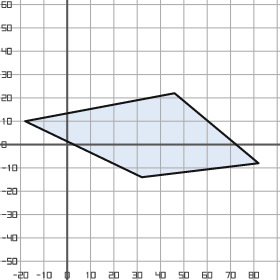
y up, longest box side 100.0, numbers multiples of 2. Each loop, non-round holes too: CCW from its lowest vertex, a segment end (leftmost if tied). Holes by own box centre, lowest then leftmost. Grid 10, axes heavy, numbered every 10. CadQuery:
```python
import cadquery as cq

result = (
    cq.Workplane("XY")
    .moveTo(32.0, -14.0)
    .lineTo(82.0, -8.0)
    .lineTo(46.0, 22.0)
    .lineTo(-18.0, 10.0)
    .close()
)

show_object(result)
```